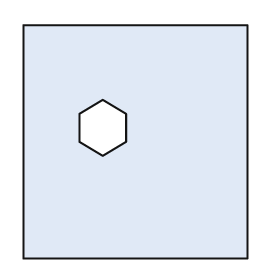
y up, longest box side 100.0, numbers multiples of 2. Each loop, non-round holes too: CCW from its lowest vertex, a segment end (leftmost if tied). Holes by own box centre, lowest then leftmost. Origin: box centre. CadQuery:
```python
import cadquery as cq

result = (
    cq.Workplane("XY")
    .moveTo(-48.0, -50.0)
    .lineTo(48.0, -50.0)
    .lineTo(48.0, 50.0)
    .lineTo(-48.0, 50.0)
    .close()
    .moveTo(-14.0, -6.0)
    .lineTo(-4.0, 0.0)
    .lineTo(-4.0, 12.0)
    .lineTo(-14.0, 18.0)
    .lineTo(-24.0, 12.0)
    .lineTo(-24.0, 0.0)
    .close()
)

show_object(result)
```